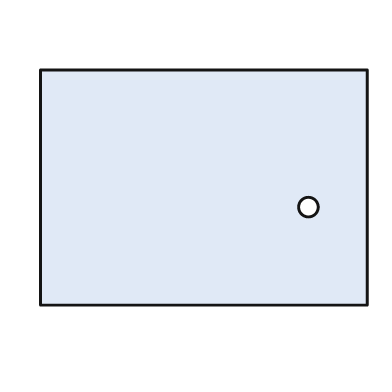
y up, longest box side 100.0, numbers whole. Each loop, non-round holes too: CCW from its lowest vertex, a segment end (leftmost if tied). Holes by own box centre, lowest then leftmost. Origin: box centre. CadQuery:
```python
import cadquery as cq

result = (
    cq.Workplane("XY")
    .moveTo(-50.0, -36.0)
    .lineTo(50.0, -36.0)
    .lineTo(50.0, 36.0)
    .lineTo(-50.0, 36.0)
    .close()
    .moveTo(32.0, -6.0)
    .circle(3.0)
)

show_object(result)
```